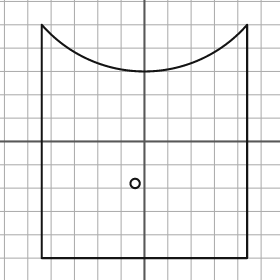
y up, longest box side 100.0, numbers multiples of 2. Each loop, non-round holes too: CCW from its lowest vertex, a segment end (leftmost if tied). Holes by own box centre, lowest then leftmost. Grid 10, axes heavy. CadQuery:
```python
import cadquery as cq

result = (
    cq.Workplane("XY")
    .moveTo(-44.0, -50.0)
    .lineTo(44.0, -50.0)
    .lineTo(44.0, 50.0)
    .threePointArc((0.0, 30.0), (-44.0, 50.0))
    .close()
    .moveTo(-4.0, -18.0)
    .circle(2.0)
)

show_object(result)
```